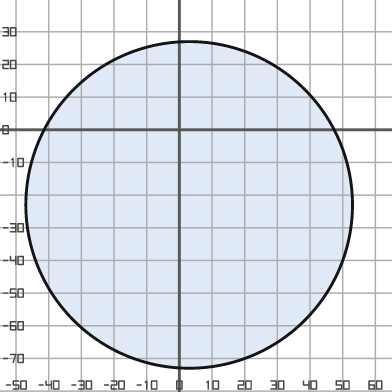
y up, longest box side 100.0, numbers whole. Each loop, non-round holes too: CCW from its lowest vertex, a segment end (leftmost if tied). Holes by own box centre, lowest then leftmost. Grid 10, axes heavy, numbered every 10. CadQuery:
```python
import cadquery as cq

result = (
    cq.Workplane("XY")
    .moveTo(3.0, -23.0)
    .circle(50.0)
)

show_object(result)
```